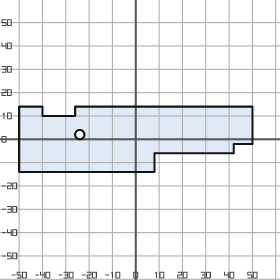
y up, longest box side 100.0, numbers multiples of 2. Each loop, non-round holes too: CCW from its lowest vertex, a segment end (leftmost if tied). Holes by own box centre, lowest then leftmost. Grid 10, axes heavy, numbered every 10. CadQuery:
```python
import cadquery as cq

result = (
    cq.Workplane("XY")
    .moveTo(-50.0, -14.0)
    .lineTo(8.0, -14.0)
    .lineTo(8.0, -6.0)
    .lineTo(42.0, -6.0)
    .lineTo(42.0, -2.0)
    .lineTo(50.0, -2.0)
    .lineTo(50.0, 14.0)
    .lineTo(-26.0, 14.0)
    .lineTo(-26.0, 10.0)
    .lineTo(-40.0, 10.0)
    .lineTo(-40.0, 14.0)
    .lineTo(-50.0, 14.0)
    .close()
    .moveTo(-24.0, 2.0)
    .circle(2.0)
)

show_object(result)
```